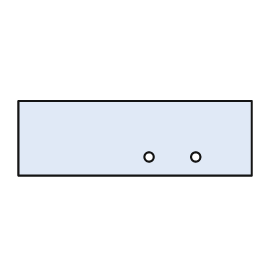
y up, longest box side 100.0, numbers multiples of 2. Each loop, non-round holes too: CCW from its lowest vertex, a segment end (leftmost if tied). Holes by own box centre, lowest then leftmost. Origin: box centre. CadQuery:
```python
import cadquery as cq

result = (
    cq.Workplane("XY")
    .moveTo(-50.0, -16.0)
    .lineTo(50.0, -16.0)
    .lineTo(50.0, 16.0)
    .lineTo(-50.0, 16.0)
    .close()
    .moveTo(6.0, -8.0)
    .circle(2.0)
    .moveTo(26.0, -8.0)
    .circle(2.0)
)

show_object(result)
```